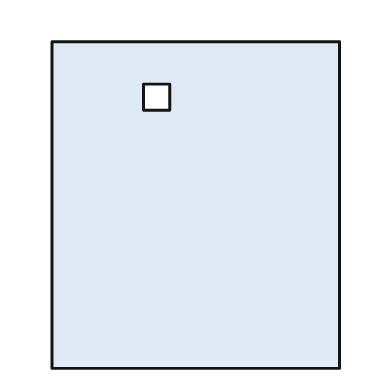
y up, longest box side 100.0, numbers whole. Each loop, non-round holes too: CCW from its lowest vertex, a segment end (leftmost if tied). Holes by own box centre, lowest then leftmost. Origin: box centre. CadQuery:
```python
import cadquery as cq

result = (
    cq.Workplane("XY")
    .moveTo(-44.0, -50.0)
    .lineTo(44.0, -50.0)
    .lineTo(44.0, 50.0)
    .lineTo(-44.0, 50.0)
    .close()
    .moveTo(-16.0, 29.0)
    .lineTo(-8.0, 29.0)
    .lineTo(-8.0, 37.0)
    .lineTo(-16.0, 37.0)
    .close()
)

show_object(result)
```